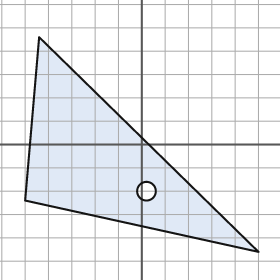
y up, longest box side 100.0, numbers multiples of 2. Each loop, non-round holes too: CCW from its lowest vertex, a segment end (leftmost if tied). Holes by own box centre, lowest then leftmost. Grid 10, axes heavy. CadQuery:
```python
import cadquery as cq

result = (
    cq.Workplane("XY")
    .moveTo(50.0, -46.0)
    .lineTo(-44.0, 46.0)
    .lineTo(-50.0, -24.0)
    .close()
    .moveTo(2.0, -20.0)
    .circle(4.0)
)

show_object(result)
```